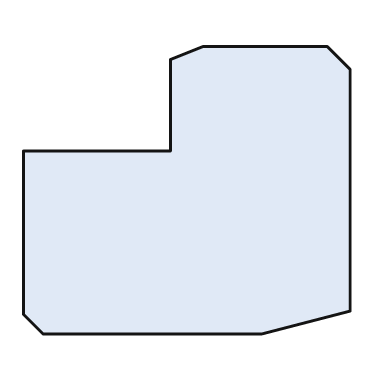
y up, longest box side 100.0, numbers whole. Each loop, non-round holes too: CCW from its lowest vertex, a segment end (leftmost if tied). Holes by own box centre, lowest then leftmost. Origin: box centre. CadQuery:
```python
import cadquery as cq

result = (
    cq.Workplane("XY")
    .moveTo(-44.0, -44.0)
    .lineTo(23.0, -44.0)
    .lineTo(50.0, -37.0)
    .lineTo(50.0, 37.0)
    .lineTo(43.0, 44.0)
    .lineTo(5.0, 44.0)
    .lineTo(-5.0, 40.0)
    .lineTo(-5.0, 12.0)
    .lineTo(-50.0, 12.0)
    .lineTo(-50.0, -38.0)
    .close()
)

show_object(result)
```